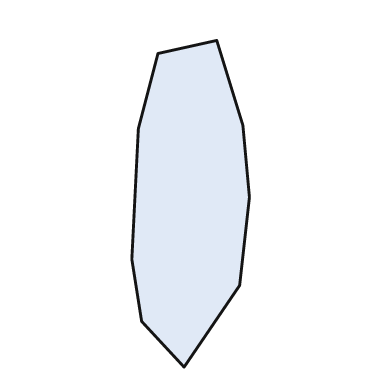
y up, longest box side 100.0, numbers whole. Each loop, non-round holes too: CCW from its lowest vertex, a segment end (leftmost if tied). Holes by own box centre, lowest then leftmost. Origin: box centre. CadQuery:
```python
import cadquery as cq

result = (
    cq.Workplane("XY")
    .moveTo(-2.0, -50.0)
    .lineTo(15.0, -25.0)
    .lineTo(18.0, 2.0)
    .lineTo(16.0, 24.0)
    .lineTo(8.0, 50.0)
    .lineTo(-10.0, 46.0)
    .lineTo(-16.0, 23.0)
    .lineTo(-18.0, -17.0)
    .lineTo(-15.0, -36.0)
    .close()
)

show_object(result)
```